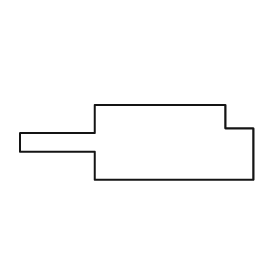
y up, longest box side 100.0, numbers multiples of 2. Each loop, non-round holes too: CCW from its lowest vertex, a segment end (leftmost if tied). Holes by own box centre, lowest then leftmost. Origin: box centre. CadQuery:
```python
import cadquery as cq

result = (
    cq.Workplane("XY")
    .moveTo(-18.0, -16.0)
    .lineTo(50.0, -16.0)
    .lineTo(50.0, 6.0)
    .lineTo(38.0, 6.0)
    .lineTo(38.0, 16.0)
    .lineTo(-18.0, 16.0)
    .lineTo(-18.0, 4.0)
    .lineTo(-50.0, 4.0)
    .lineTo(-50.0, -4.0)
    .lineTo(-18.0, -4.0)
    .close()
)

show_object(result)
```